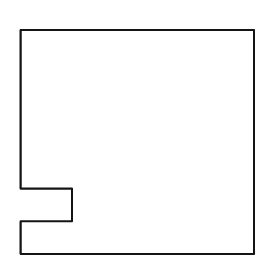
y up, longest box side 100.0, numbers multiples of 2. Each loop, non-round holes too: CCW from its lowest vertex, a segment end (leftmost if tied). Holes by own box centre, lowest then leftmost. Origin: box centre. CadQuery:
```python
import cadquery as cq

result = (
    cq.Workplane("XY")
    .moveTo(-50.0, -48.0)
    .lineTo(50.0, -48.0)
    .lineTo(50.0, 48.0)
    .lineTo(-50.0, 48.0)
    .lineTo(-50.0, -20.0)
    .lineTo(-28.0, -20.0)
    .lineTo(-28.0, -34.0)
    .lineTo(-50.0, -34.0)
    .close()
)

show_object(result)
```